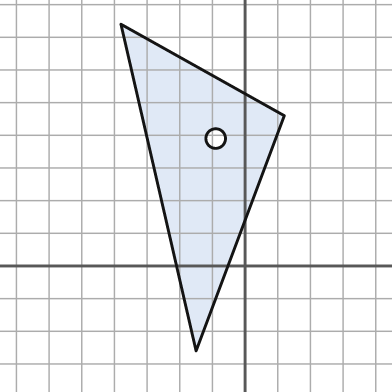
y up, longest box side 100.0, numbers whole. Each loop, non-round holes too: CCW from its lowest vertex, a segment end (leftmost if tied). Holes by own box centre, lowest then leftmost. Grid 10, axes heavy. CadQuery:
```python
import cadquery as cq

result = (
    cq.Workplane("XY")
    .moveTo(-15.0, -26.0)
    .lineTo(12.0, 46.0)
    .lineTo(-38.0, 74.0)
    .close()
    .moveTo(-9.0, 39.0)
    .circle(3.0)
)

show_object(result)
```